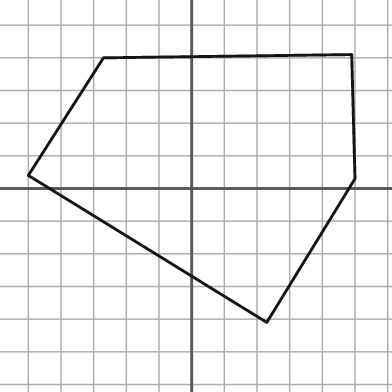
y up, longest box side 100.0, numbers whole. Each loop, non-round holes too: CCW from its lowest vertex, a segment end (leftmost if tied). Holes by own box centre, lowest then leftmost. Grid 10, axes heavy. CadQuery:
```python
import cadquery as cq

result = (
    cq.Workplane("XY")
    .moveTo(23.0, -41.0)
    .lineTo(50.0, 3.0)
    .lineTo(49.0, 41.0)
    .lineTo(-27.0, 40.0)
    .lineTo(-50.0, 4.0)
    .close()
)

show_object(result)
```